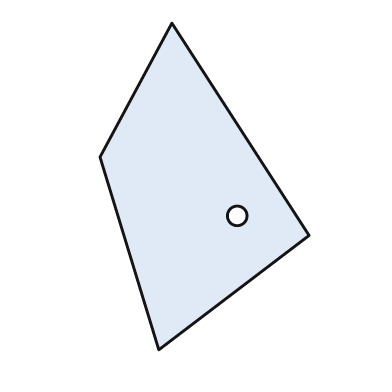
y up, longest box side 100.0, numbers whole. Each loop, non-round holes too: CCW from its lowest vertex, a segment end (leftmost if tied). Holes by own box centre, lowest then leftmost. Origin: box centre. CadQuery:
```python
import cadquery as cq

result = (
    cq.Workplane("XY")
    .moveTo(-14.0, -50.0)
    .lineTo(32.0, -15.0)
    .lineTo(-10.0, 50.0)
    .lineTo(-32.0, 9.0)
    .close()
    .moveTo(10.0, -9.0)
    .circle(3.0)
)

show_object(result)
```